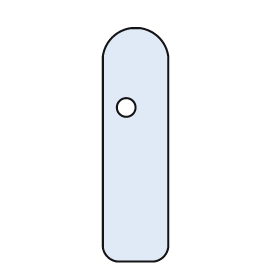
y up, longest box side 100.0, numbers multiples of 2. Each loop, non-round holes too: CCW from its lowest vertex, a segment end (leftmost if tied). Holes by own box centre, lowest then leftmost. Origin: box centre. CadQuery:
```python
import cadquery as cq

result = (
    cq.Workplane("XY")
    .moveTo(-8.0, -50.0)
    .lineTo(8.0, -50.0)
    .threePointArc((12.0, -48.0), (14.0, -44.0))
    .lineTo(14.0, 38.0)
    .threePointArc((10.0, 46.0), (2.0, 50.0))
    .lineTo(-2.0, 50.0)
    .threePointArc((-10.0, 46.0), (-14.0, 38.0))
    .lineTo(-14.0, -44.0)
    .threePointArc((-12.0, -48.0), (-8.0, -50.0))
    .close()
    .moveTo(-4.0, 16.0)
    .circle(4.0)
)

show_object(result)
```